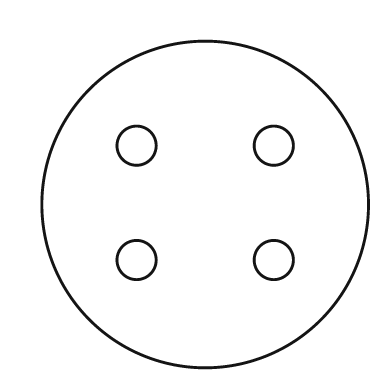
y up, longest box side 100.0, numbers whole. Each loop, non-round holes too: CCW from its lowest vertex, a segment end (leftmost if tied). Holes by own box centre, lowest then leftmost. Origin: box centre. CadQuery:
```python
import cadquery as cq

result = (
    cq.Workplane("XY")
    .moveTo(0.0, 0.0)
    .circle(50.0)
    .moveTo(-21.0, -17.0)
    .circle(6.0)
    .moveTo(21.0, -17.0)
    .circle(6.0)
    .moveTo(-21.0, 18.0)
    .circle(6.0)
    .moveTo(21.0, 18.0)
    .circle(6.0)
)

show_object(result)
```